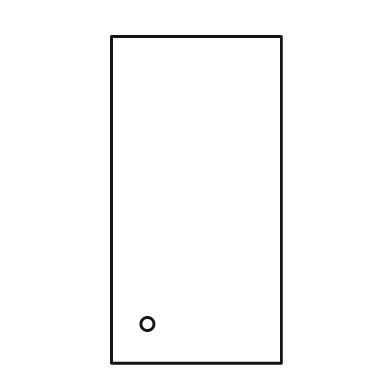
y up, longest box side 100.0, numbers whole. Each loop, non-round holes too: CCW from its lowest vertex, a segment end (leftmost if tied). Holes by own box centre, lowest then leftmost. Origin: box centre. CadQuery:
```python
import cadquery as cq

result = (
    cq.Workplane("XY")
    .moveTo(-26.0, -50.0)
    .lineTo(26.0, -50.0)
    .lineTo(26.0, 50.0)
    .lineTo(-26.0, 50.0)
    .close()
    .moveTo(-15.0, -38.0)
    .circle(2.0)
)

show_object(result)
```